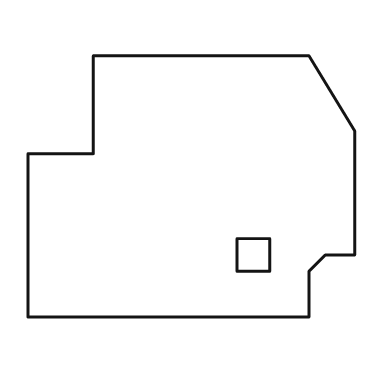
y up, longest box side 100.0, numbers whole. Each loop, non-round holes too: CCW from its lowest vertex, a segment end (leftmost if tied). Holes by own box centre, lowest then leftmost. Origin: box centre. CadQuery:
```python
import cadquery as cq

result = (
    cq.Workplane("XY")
    .moveTo(-50.0, -40.0)
    .lineTo(36.0, -40.0)
    .lineTo(36.0, -26.0)
    .lineTo(41.0, -21.0)
    .lineTo(50.0, -21.0)
    .lineTo(50.0, 17.0)
    .lineTo(36.0, 40.0)
    .lineTo(-30.0, 40.0)
    .lineTo(-30.0, 10.0)
    .lineTo(-50.0, 10.0)
    .close()
    .moveTo(14.0, -26.0)
    .lineTo(24.0, -26.0)
    .lineTo(24.0, -16.0)
    .lineTo(14.0, -16.0)
    .close()
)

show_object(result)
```